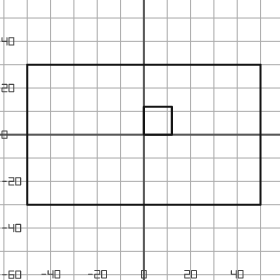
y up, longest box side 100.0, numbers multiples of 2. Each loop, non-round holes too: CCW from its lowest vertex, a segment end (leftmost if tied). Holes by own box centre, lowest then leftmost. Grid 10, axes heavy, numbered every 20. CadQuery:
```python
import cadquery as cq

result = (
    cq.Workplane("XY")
    .moveTo(-50.0, -30.0)
    .lineTo(50.0, -30.0)
    .lineTo(50.0, 30.0)
    .lineTo(-50.0, 30.0)
    .close()
    .moveTo(0.0, 0.0)
    .lineTo(12.0, 0.0)
    .lineTo(12.0, 12.0)
    .lineTo(0.0, 12.0)
    .close()
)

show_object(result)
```